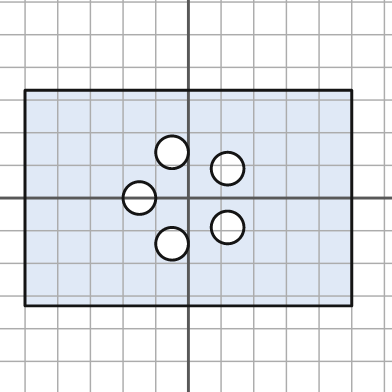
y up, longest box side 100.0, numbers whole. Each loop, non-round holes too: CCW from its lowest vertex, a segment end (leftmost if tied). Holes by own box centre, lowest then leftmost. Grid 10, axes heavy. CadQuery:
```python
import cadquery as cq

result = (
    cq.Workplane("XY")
    .moveTo(-50.0, -33.0)
    .lineTo(50.0, -33.0)
    .lineTo(50.0, 33.0)
    .lineTo(-50.0, 33.0)
    .close()
    .moveTo(-5.0, -14.0)
    .circle(5.0)
    .moveTo(12.0, -9.0)
    .circle(5.0)
    .moveTo(-15.0, 0.0)
    .circle(5.0)
    .moveTo(12.0, 9.0)
    .circle(5.0)
    .moveTo(-5.0, 14.0)
    .circle(5.0)
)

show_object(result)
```